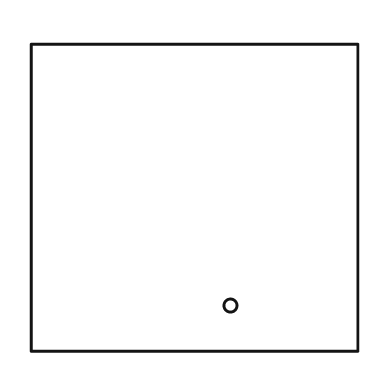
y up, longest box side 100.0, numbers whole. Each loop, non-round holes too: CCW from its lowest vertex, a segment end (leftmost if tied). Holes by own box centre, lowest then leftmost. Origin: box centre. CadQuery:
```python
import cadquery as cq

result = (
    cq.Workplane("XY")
    .moveTo(-50.0, -47.0)
    .lineTo(50.0, -47.0)
    .lineTo(50.0, 47.0)
    .lineTo(-50.0, 47.0)
    .close()
    .moveTo(11.0, -33.0)
    .circle(2.0)
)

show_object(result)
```